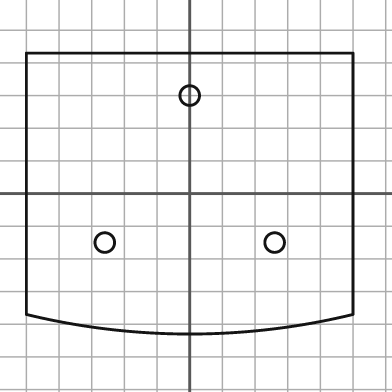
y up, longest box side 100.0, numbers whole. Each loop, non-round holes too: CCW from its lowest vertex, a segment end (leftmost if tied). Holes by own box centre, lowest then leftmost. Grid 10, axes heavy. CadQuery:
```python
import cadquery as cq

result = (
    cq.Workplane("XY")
    .moveTo(-50.0, -37.0)
    .threePointArc((0.0, -43.0), (50.0, -37.0))
    .lineTo(50.0, 43.0)
    .lineTo(-50.0, 43.0)
    .close()
    .moveTo(-26.0, -15.0)
    .circle(3.0)
    .moveTo(26.0, -15.0)
    .circle(3.0)
    .moveTo(0.0, 30.0)
    .circle(3.0)
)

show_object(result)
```